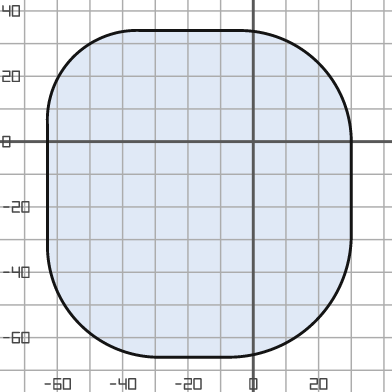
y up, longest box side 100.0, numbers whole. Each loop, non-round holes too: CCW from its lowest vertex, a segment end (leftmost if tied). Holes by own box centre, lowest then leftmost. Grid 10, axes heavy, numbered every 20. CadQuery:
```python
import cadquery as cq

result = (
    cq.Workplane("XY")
    .moveTo(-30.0, -66.0)
    .lineTo(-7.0, -66.0)
    .threePointArc((19.0, -55.0), (30.0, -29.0))
    .lineTo(30.0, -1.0)
    .threePointArc((20.0, 24.0), (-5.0, 34.0))
    .lineTo(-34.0, 34.0)
    .threePointArc((-55.0, 26.0), (-63.0, 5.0))
    .lineTo(-63.0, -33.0)
    .threePointArc((-53.0, -56.0), (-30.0, -66.0))
    .close()
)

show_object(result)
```